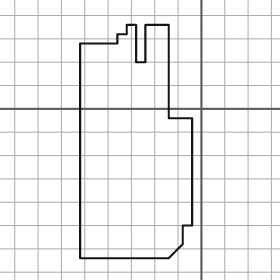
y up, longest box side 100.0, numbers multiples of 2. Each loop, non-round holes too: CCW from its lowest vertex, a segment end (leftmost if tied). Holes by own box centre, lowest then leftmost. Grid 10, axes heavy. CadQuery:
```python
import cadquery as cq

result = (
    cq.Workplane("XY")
    .moveTo(-52.0, -64.0)
    .lineTo(-14.0, -64.0)
    .lineTo(-8.0, -58.0)
    .lineTo(-8.0, -50.0)
    .lineTo(-4.0, -50.0)
    .lineTo(-4.0, -4.0)
    .lineTo(-14.0, -4.0)
    .lineTo(-14.0, 36.0)
    .lineTo(-24.0, 36.0)
    .lineTo(-24.0, 20.0)
    .lineTo(-28.0, 20.0)
    .lineTo(-28.0, 36.0)
    .lineTo(-32.0, 36.0)
    .lineTo(-32.0, 32.0)
    .lineTo(-36.0, 32.0)
    .lineTo(-36.0, 28.0)
    .lineTo(-52.0, 28.0)
    .close()
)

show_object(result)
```